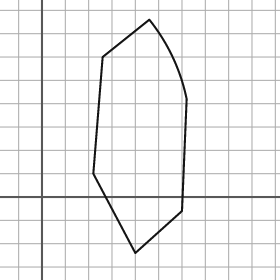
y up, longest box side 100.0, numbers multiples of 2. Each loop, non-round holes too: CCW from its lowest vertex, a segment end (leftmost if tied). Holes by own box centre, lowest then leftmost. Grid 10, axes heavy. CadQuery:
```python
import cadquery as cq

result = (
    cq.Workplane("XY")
    .moveTo(40.0, -24.0)
    .lineTo(60.0, -6.0)
    .lineTo(62.0, 42.0)
    .threePointArc((56.0, 60.0), (46.0, 76.0))
    .lineTo(26.0, 60.0)
    .lineTo(22.0, 10.0)
    .close()
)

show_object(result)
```